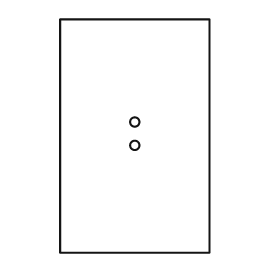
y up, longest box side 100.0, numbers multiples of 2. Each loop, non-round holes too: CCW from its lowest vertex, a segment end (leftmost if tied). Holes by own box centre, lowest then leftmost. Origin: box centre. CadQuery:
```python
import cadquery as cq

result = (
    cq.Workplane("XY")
    .moveTo(-32.0, -50.0)
    .lineTo(32.0, -50.0)
    .lineTo(32.0, 50.0)
    .lineTo(-32.0, 50.0)
    .close()
    .moveTo(0.0, -4.0)
    .circle(2.0)
    .moveTo(0.0, 6.0)
    .circle(2.0)
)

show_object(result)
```